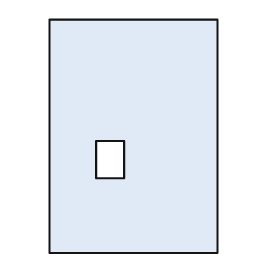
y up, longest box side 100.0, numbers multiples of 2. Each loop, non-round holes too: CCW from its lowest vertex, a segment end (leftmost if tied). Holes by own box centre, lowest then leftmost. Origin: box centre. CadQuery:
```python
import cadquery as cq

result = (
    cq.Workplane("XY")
    .moveTo(-36.0, -50.0)
    .lineTo(36.0, -50.0)
    .lineTo(36.0, 50.0)
    .lineTo(-36.0, 50.0)
    .close()
    .moveTo(-16.0, -18.0)
    .lineTo(-4.0, -18.0)
    .lineTo(-4.0, -2.0)
    .lineTo(-16.0, -2.0)
    .close()
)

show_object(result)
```